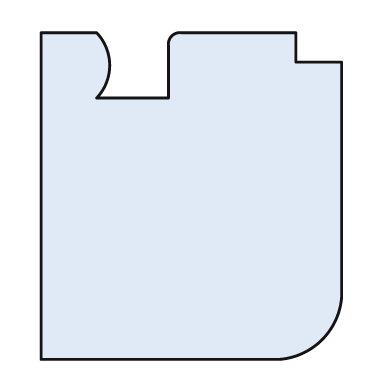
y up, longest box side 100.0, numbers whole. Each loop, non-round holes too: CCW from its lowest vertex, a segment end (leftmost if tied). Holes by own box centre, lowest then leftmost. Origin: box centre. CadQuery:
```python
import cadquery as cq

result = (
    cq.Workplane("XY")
    .moveTo(-46.0, -50.0)
    .lineTo(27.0, -50.0)
    .threePointArc((40.0, -44.0), (46.0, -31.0))
    .lineTo(46.0, 41.0)
    .lineTo(32.0, 41.0)
    .lineTo(32.0, 50.0)
    .lineTo(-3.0, 50.0)
    .threePointArc((-6.0, 49.0), (-7.0, 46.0))
    .lineTo(-7.0, 30.0)
    .lineTo(-29.0, 30.0)
    .threePointArc((-25.0, 40.0), (-29.0, 50.0))
    .lineTo(-46.0, 50.0)
    .close()
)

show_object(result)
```